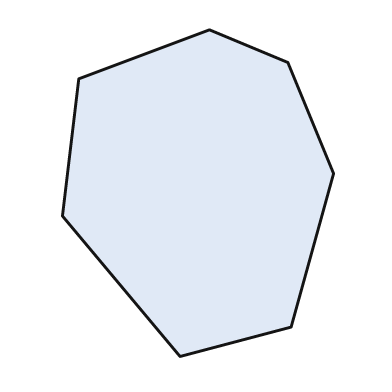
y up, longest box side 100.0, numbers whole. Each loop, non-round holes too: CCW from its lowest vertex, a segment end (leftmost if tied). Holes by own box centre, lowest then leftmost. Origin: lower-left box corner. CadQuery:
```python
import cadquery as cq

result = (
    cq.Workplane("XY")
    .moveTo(36.0, 0.0)
    .lineTo(70.0, 9.0)
    .lineTo(83.0, 56.0)
    .lineTo(69.0, 90.0)
    .lineTo(45.0, 100.0)
    .lineTo(5.0, 85.0)
    .lineTo(0.0, 43.0)
    .close()
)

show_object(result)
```